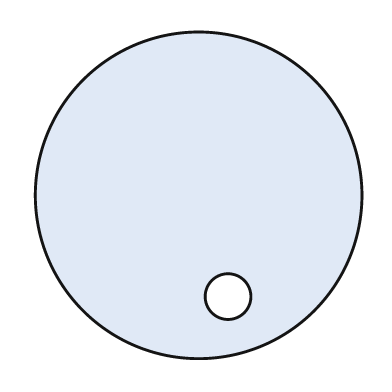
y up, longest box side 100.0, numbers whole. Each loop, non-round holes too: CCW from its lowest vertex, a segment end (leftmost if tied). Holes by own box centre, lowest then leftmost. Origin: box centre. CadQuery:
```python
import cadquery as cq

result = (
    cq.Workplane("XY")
    .moveTo(0.0, 0.0)
    .circle(50.0)
    .moveTo(9.0, -31.0)
    .circle(7.0)
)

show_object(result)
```